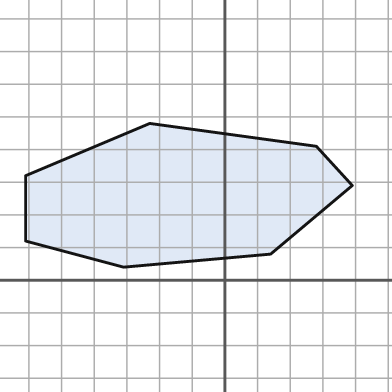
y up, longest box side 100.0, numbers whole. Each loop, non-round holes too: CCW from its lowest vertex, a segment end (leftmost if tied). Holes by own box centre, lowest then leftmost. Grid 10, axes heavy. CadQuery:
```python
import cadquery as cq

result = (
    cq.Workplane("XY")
    .moveTo(-31.0, 4.0)
    .lineTo(14.0, 8.0)
    .lineTo(39.0, 29.0)
    .lineTo(28.0, 41.0)
    .lineTo(-23.0, 48.0)
    .lineTo(-61.0, 32.0)
    .lineTo(-61.0, 12.0)
    .close()
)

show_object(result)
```